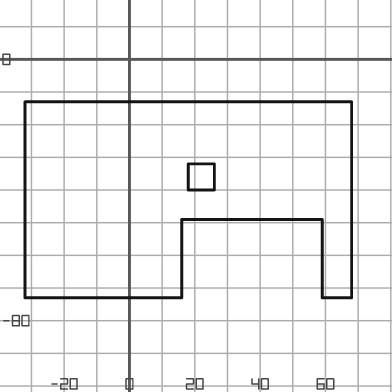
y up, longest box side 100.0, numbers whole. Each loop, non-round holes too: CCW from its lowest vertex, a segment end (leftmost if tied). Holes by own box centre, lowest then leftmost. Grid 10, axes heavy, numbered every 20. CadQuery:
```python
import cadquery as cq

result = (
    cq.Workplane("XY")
    .moveTo(-32.0, -73.0)
    .lineTo(16.0, -73.0)
    .lineTo(16.0, -49.0)
    .lineTo(59.0, -49.0)
    .lineTo(59.0, -73.0)
    .lineTo(68.0, -73.0)
    .lineTo(68.0, -13.0)
    .lineTo(-32.0, -13.0)
    .close()
    .moveTo(18.0, -40.0)
    .lineTo(26.0, -40.0)
    .lineTo(26.0, -32.0)
    .lineTo(18.0, -32.0)
    .close()
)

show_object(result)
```